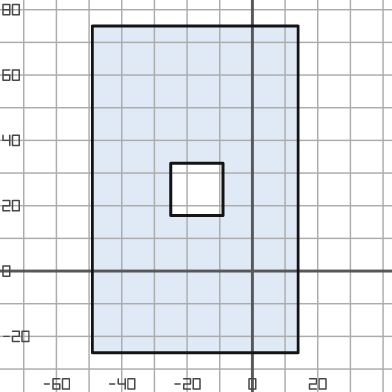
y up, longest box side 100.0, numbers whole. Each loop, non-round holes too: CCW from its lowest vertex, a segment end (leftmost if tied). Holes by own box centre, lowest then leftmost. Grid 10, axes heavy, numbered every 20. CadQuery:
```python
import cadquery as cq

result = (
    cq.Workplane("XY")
    .moveTo(-49.0, -25.0)
    .lineTo(14.0, -25.0)
    .lineTo(14.0, 75.0)
    .lineTo(-49.0, 75.0)
    .close()
    .moveTo(-25.0, 17.0)
    .lineTo(-9.0, 17.0)
    .lineTo(-9.0, 33.0)
    .lineTo(-25.0, 33.0)
    .close()
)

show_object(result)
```